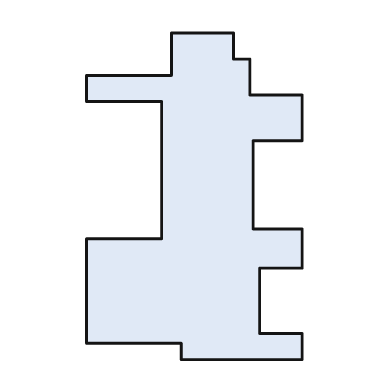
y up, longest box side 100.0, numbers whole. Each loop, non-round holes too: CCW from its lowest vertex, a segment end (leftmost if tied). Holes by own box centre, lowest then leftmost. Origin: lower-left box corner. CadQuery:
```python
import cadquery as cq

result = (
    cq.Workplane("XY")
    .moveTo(29.0, 0.0)
    .lineTo(66.0, 0.0)
    .lineTo(66.0, 8.0)
    .lineTo(53.0, 8.0)
    .lineTo(53.0, 28.0)
    .lineTo(66.0, 28.0)
    .lineTo(66.0, 40.0)
    .lineTo(51.0, 40.0)
    .lineTo(51.0, 67.0)
    .lineTo(66.0, 67.0)
    .lineTo(66.0, 81.0)
    .lineTo(50.0, 81.0)
    .lineTo(50.0, 92.0)
    .lineTo(45.0, 92.0)
    .lineTo(45.0, 100.0)
    .lineTo(26.0, 100.0)
    .lineTo(26.0, 87.0)
    .lineTo(0.0, 87.0)
    .lineTo(0.0, 79.0)
    .lineTo(23.0, 79.0)
    .lineTo(23.0, 37.0)
    .lineTo(0.0, 37.0)
    .lineTo(0.0, 5.0)
    .lineTo(29.0, 5.0)
    .close()
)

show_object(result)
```